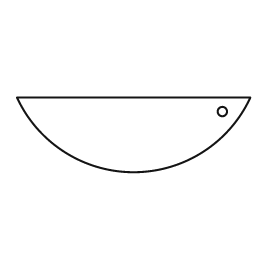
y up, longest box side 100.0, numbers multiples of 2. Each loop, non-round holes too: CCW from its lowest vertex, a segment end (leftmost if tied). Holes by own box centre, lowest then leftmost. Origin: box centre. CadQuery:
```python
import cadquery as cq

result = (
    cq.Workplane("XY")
    .moveTo(-50.0, 16.0)
    .threePointArc((0.0, -16.0), (50.0, 16.0))
    .close()
    .moveTo(38.0, 10.0)
    .circle(2.0)
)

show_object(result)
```